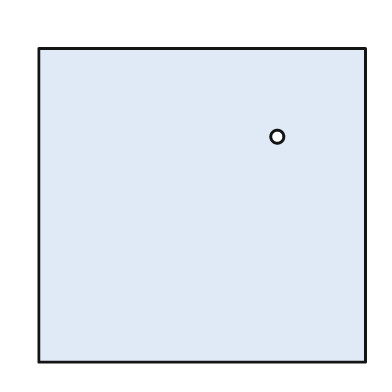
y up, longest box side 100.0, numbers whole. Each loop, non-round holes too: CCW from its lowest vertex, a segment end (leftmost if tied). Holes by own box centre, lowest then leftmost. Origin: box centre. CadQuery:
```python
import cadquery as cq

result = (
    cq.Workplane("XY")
    .moveTo(-50.0, -48.0)
    .lineTo(50.0, -48.0)
    .lineTo(50.0, 48.0)
    .lineTo(-50.0, 48.0)
    .close()
    .moveTo(23.0, 21.0)
    .circle(2.0)
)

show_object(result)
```